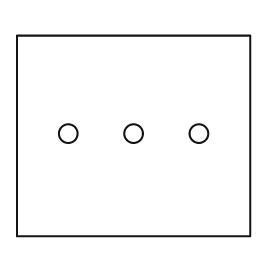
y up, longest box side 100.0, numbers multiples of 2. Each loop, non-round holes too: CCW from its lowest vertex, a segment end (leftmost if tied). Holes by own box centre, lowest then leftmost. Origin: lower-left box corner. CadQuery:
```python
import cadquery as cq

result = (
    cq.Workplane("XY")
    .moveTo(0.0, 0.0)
    .lineTo(100.0, 0.0)
    .lineTo(100.0, 86.0)
    .lineTo(0.0, 86.0)
    .close()
    .moveTo(22.0, 44.0)
    .circle(4.0)
    .moveTo(50.0, 44.0)
    .circle(4.0)
    .moveTo(78.0, 44.0)
    .circle(4.0)
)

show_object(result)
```